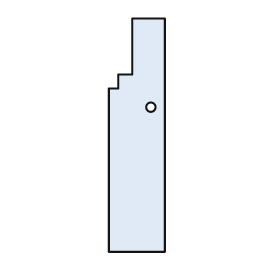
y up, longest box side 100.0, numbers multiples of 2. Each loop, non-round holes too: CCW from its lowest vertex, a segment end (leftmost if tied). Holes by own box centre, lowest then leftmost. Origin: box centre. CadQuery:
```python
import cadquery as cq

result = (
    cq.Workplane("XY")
    .moveTo(-12.0, -50.0)
    .lineTo(12.0, -50.0)
    .lineTo(12.0, 50.0)
    .lineTo(-2.0, 50.0)
    .lineTo(-2.0, 26.0)
    .lineTo(-8.0, 26.0)
    .lineTo(-8.0, 20.0)
    .lineTo(-12.0, 20.0)
    .close()
    .moveTo(6.0, 12.0)
    .circle(2.0)
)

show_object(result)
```